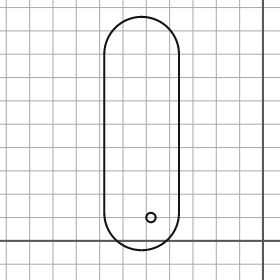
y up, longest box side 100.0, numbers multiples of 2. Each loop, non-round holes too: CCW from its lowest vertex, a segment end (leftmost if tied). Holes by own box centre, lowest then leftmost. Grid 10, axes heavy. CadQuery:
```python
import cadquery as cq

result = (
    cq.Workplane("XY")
    .moveTo(-68.0, 12.0)
    .threePointArc((-52.0, -4.0), (-36.0, 12.0))
    .lineTo(-36.0, 80.0)
    .threePointArc((-52.0, 96.0), (-68.0, 80.0))
    .close()
    .moveTo(-48.0, 10.0)
    .circle(2.0)
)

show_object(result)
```